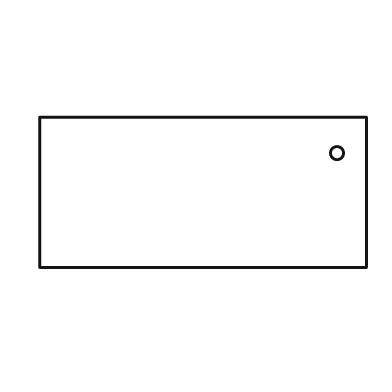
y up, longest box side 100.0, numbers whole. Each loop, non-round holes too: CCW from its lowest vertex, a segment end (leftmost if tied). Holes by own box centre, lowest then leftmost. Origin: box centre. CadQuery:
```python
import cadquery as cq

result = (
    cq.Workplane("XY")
    .moveTo(-50.0, -23.0)
    .lineTo(50.0, -23.0)
    .lineTo(50.0, 23.0)
    .lineTo(-50.0, 23.0)
    .close()
    .moveTo(41.0, 12.0)
    .circle(2.0)
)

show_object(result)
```